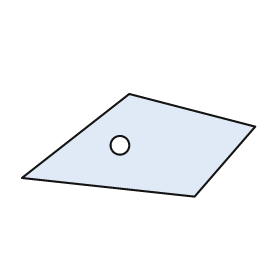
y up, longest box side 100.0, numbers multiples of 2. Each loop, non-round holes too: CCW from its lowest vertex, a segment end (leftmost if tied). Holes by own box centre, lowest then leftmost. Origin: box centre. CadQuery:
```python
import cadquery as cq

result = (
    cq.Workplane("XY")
    .moveTo(24.0, -22.0)
    .lineTo(50.0, 8.0)
    .lineTo(-4.0, 22.0)
    .lineTo(-50.0, -14.0)
    .close()
    .moveTo(-8.0, 0.0)
    .circle(4.0)
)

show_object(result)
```